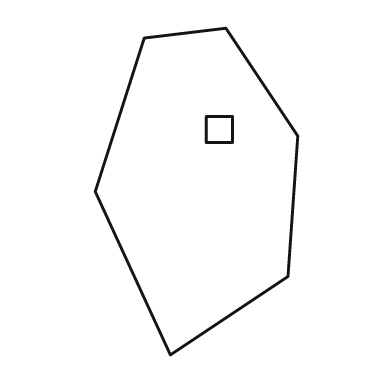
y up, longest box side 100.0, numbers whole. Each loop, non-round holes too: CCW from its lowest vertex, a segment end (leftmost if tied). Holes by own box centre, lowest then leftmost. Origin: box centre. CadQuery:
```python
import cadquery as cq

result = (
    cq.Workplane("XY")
    .moveTo(-8.0, -50.0)
    .lineTo(28.0, -26.0)
    .lineTo(31.0, 17.0)
    .lineTo(9.0, 50.0)
    .lineTo(-16.0, 47.0)
    .lineTo(-31.0, 0.0)
    .close()
    .moveTo(3.0, 15.0)
    .lineTo(11.0, 15.0)
    .lineTo(11.0, 23.0)
    .lineTo(3.0, 23.0)
    .close()
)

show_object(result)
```